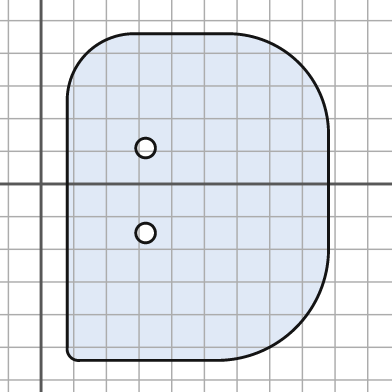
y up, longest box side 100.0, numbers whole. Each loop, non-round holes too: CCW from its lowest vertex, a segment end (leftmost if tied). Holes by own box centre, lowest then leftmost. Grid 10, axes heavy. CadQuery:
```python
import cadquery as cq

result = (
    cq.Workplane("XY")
    .moveTo(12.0, -54.0)
    .lineTo(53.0, -54.0)
    .threePointArc((78.0, -44.0), (88.0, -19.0))
    .lineTo(88.0, 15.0)
    .threePointArc((79.0, 37.0), (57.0, 46.0))
    .lineTo(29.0, 46.0)
    .threePointArc((14.0, 40.0), (8.0, 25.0))
    .lineTo(8.0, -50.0)
    .threePointArc((9.0, -53.0), (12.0, -54.0))
    .close()
    .moveTo(32.0, -15.0)
    .circle(3.0)
    .moveTo(32.0, 11.0)
    .circle(3.0)
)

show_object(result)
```